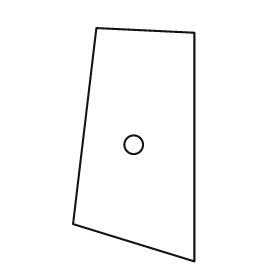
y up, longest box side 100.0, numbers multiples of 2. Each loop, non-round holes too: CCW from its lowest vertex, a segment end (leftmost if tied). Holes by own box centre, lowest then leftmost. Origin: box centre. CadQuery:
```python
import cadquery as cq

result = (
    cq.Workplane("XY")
    .moveTo(26.0, -50.0)
    .lineTo(26.0, 48.0)
    .lineTo(-16.0, 50.0)
    .lineTo(-26.0, -34.0)
    .close()
    .moveTo(0.0, 0.0)
    .circle(4.0)
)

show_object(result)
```